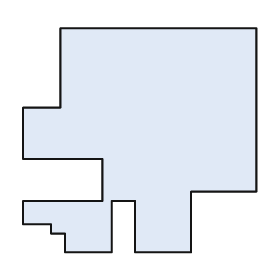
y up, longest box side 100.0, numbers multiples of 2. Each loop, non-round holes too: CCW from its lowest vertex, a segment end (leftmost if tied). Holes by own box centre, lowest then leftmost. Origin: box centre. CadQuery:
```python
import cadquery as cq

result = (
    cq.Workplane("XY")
    .moveTo(-32.0, -48.0)
    .lineTo(-12.0, -48.0)
    .lineTo(-12.0, -26.0)
    .lineTo(-2.0, -26.0)
    .lineTo(-2.0, -48.0)
    .lineTo(22.0, -48.0)
    .lineTo(22.0, -22.0)
    .lineTo(50.0, -22.0)
    .lineTo(50.0, 48.0)
    .lineTo(-34.0, 48.0)
    .lineTo(-34.0, 14.0)
    .lineTo(-50.0, 14.0)
    .lineTo(-50.0, -8.0)
    .lineTo(-16.0, -8.0)
    .lineTo(-16.0, -26.0)
    .lineTo(-50.0, -26.0)
    .lineTo(-50.0, -36.0)
    .lineTo(-38.0, -36.0)
    .lineTo(-38.0, -40.0)
    .lineTo(-32.0, -40.0)
    .close()
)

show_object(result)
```